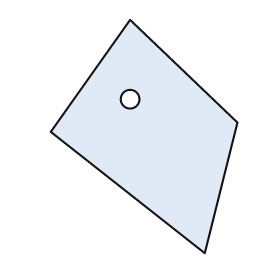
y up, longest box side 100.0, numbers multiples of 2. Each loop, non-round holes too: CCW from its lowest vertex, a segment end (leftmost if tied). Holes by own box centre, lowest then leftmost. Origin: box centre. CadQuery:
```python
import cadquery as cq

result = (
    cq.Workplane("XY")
    .moveTo(26.0, -50.0)
    .lineTo(40.0, 6.0)
    .lineTo(-6.0, 50.0)
    .lineTo(-40.0, 2.0)
    .close()
    .moveTo(-6.0, 16.0)
    .circle(4.0)
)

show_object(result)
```